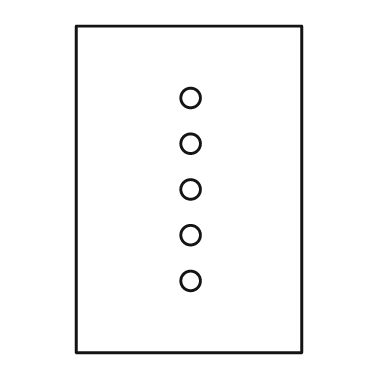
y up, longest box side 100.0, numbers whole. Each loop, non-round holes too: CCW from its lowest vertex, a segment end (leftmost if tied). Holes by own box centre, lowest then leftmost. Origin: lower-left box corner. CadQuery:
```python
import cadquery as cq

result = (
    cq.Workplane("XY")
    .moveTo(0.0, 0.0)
    .lineTo(69.0, 0.0)
    .lineTo(69.0, 100.0)
    .lineTo(0.0, 100.0)
    .close()
    .moveTo(35.0, 22.0)
    .circle(3.0)
    .moveTo(35.0, 36.0)
    .circle(3.0)
    .moveTo(35.0, 50.0)
    .circle(3.0)
    .moveTo(35.0, 64.0)
    .circle(3.0)
    .moveTo(35.0, 78.0)
    .circle(3.0)
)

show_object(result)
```